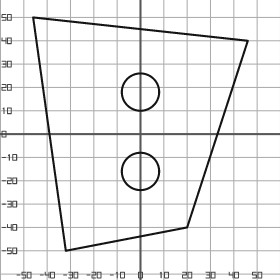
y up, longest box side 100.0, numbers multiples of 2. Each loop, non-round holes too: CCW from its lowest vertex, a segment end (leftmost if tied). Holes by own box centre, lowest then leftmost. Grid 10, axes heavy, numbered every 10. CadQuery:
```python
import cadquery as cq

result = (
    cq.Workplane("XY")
    .moveTo(-32.0, -50.0)
    .lineTo(20.0, -40.0)
    .lineTo(46.0, 40.0)
    .lineTo(-46.0, 50.0)
    .close()
    .moveTo(0.0, -16.0)
    .circle(8.0)
    .moveTo(0.0, 18.0)
    .circle(8.0)
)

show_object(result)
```